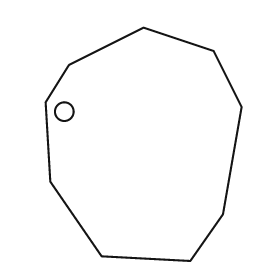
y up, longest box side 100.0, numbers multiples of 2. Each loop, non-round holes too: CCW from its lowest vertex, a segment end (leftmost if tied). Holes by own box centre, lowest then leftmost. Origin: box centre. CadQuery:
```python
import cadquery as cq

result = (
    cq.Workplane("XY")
    .moveTo(20.0, -50.0)
    .lineTo(34.0, -30.0)
    .lineTo(42.0, 16.0)
    .lineTo(30.0, 40.0)
    .lineTo(0.0, 50.0)
    .lineTo(-32.0, 34.0)
    .lineTo(-42.0, 18.0)
    .lineTo(-40.0, -16.0)
    .lineTo(-18.0, -48.0)
    .close()
    .moveTo(-34.0, 14.0)
    .circle(4.0)
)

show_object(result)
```